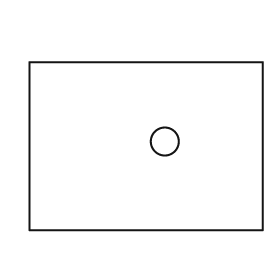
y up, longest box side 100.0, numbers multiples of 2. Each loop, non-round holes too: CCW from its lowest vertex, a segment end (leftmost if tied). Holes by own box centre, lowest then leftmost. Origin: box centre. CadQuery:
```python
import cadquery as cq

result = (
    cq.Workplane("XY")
    .moveTo(-50.0, -36.0)
    .lineTo(50.0, -36.0)
    .lineTo(50.0, 36.0)
    .lineTo(-50.0, 36.0)
    .close()
    .moveTo(8.0, 2.0)
    .circle(6.0)
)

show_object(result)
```